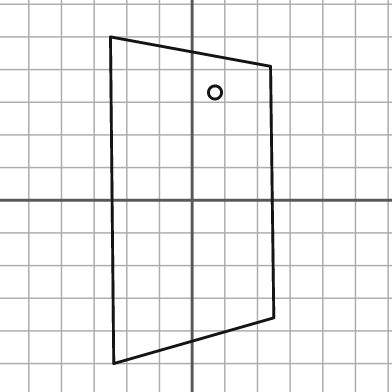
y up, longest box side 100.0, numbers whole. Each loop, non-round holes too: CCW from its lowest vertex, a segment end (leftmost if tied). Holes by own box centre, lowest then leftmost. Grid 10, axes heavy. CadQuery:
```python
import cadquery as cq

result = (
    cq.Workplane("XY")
    .moveTo(-24.0, -50.0)
    .lineTo(25.0, -36.0)
    .lineTo(24.0, 41.0)
    .lineTo(-25.0, 50.0)
    .close()
    .moveTo(7.0, 33.0)
    .circle(2.0)
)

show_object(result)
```